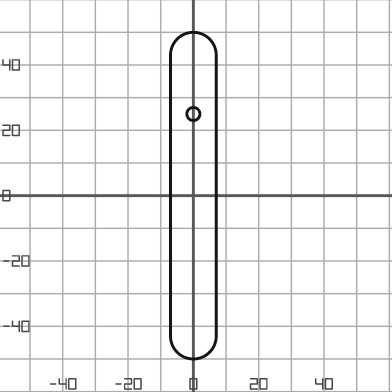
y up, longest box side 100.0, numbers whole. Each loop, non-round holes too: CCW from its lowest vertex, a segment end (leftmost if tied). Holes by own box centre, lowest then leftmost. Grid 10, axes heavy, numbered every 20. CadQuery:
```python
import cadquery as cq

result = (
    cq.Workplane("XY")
    .moveTo(-7.0, -43.0)
    .threePointArc((0.0, -50.0), (7.0, -43.0))
    .lineTo(7.0, 43.0)
    .threePointArc((0.0, 50.0), (-7.0, 43.0))
    .close()
    .moveTo(0.0, 25.0)
    .circle(2.0)
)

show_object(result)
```